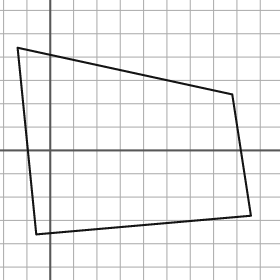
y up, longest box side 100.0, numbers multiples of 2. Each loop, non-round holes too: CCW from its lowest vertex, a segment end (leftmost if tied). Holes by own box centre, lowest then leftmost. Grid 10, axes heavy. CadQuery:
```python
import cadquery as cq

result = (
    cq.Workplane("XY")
    .moveTo(-6.0, -36.0)
    .lineTo(86.0, -28.0)
    .lineTo(78.0, 24.0)
    .lineTo(-14.0, 44.0)
    .close()
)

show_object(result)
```